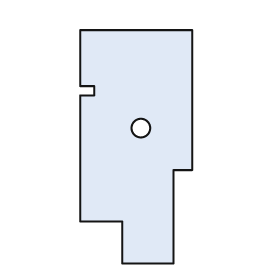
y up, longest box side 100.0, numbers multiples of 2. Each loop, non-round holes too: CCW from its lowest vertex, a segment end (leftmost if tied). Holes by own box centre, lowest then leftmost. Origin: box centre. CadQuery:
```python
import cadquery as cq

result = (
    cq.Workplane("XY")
    .moveTo(-6.0, -50.0)
    .lineTo(16.0, -50.0)
    .lineTo(16.0, -10.0)
    .lineTo(24.0, -10.0)
    .lineTo(24.0, 50.0)
    .lineTo(-24.0, 50.0)
    .lineTo(-24.0, 26.0)
    .lineTo(-18.0, 26.0)
    .lineTo(-18.0, 22.0)
    .lineTo(-24.0, 22.0)
    .lineTo(-24.0, -32.0)
    .lineTo(-6.0, -32.0)
    .close()
    .moveTo(2.0, 8.0)
    .circle(4.0)
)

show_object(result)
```